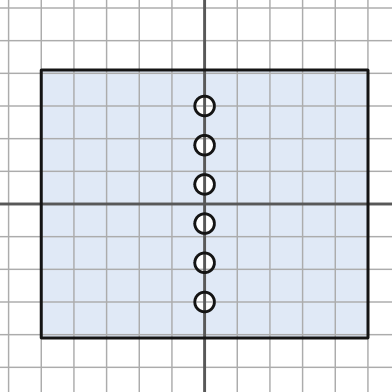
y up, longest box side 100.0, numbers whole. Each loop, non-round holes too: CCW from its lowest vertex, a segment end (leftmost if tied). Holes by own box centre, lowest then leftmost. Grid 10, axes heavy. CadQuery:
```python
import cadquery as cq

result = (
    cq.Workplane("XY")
    .moveTo(-50.0, -41.0)
    .lineTo(50.0, -41.0)
    .lineTo(50.0, 41.0)
    .lineTo(-50.0, 41.0)
    .close()
    .moveTo(0.0, -30.0)
    .circle(3.0)
    .moveTo(0.0, -18.0)
    .circle(3.0)
    .moveTo(0.0, -6.0)
    .circle(3.0)
    .moveTo(0.0, 6.0)
    .circle(3.0)
    .moveTo(0.0, 18.0)
    .circle(3.0)
    .moveTo(0.0, 30.0)
    .circle(3.0)
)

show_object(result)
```